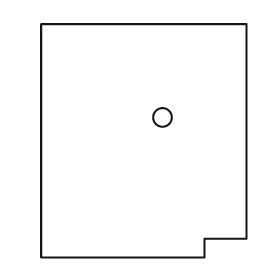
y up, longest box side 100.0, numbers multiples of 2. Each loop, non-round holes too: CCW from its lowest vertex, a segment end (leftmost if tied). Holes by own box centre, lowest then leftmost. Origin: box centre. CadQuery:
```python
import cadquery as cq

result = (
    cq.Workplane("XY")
    .moveTo(-44.0, -50.0)
    .lineTo(26.0, -50.0)
    .lineTo(26.0, -42.0)
    .lineTo(44.0, -42.0)
    .lineTo(44.0, 50.0)
    .lineTo(-44.0, 50.0)
    .close()
    .moveTo(8.0, 10.0)
    .circle(4.0)
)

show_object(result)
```